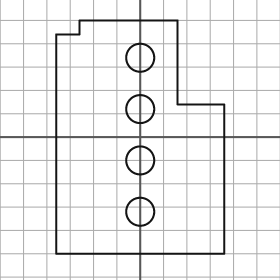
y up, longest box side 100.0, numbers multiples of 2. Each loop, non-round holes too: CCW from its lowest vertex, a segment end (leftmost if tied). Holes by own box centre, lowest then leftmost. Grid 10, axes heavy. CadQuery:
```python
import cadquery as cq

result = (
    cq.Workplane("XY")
    .moveTo(-36.0, -50.0)
    .lineTo(36.0, -50.0)
    .lineTo(36.0, 14.0)
    .lineTo(16.0, 14.0)
    .lineTo(16.0, 50.0)
    .lineTo(-26.0, 50.0)
    .lineTo(-26.0, 44.0)
    .lineTo(-36.0, 44.0)
    .close()
    .moveTo(0.0, -32.0)
    .circle(6.0)
    .moveTo(0.0, -10.0)
    .circle(6.0)
    .moveTo(0.0, 12.0)
    .circle(6.0)
    .moveTo(0.0, 34.0)
    .circle(6.0)
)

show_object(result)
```